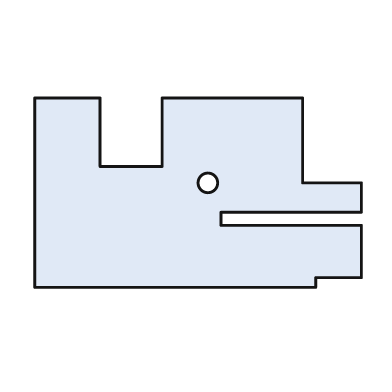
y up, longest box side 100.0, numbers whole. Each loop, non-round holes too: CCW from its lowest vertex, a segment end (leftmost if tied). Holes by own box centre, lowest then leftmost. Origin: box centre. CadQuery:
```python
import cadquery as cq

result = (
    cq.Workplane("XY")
    .moveTo(-50.0, -29.0)
    .lineTo(36.0, -29.0)
    .lineTo(36.0, -26.0)
    .lineTo(50.0, -26.0)
    .lineTo(50.0, -10.0)
    .lineTo(7.0, -10.0)
    .lineTo(7.0, -6.0)
    .lineTo(50.0, -6.0)
    .lineTo(50.0, 3.0)
    .lineTo(32.0, 3.0)
    .lineTo(32.0, 29.0)
    .lineTo(-11.0, 29.0)
    .lineTo(-11.0, 8.0)
    .lineTo(-30.0, 8.0)
    .lineTo(-30.0, 29.0)
    .lineTo(-50.0, 29.0)
    .close()
    .moveTo(3.0, 3.0)
    .circle(3.0)
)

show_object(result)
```